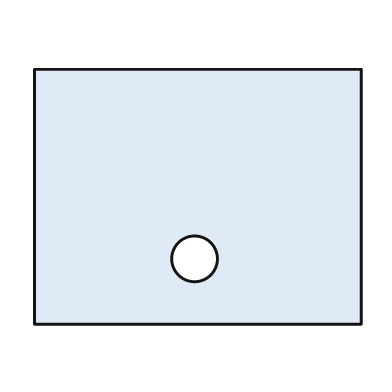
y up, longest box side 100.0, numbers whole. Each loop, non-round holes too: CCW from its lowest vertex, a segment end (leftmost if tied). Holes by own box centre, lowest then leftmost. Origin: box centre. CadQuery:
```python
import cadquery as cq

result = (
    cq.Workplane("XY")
    .moveTo(-50.0, -39.0)
    .lineTo(50.0, -39.0)
    .lineTo(50.0, 39.0)
    .lineTo(-50.0, 39.0)
    .close()
    .moveTo(-1.0, -19.0)
    .circle(7.0)
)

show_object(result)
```